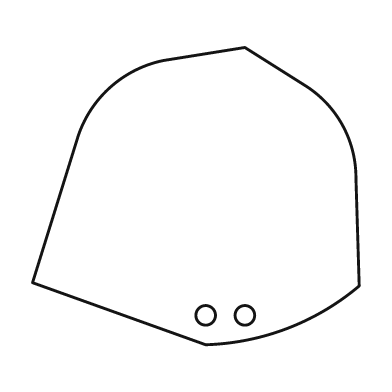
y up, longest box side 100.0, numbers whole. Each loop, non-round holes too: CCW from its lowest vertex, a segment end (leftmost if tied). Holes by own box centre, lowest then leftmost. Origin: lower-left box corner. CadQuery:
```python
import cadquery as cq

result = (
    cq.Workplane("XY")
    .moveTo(53.0, 0.0)
    .threePointArc((78.0, 5.0), (100.0, 18.0))
    .lineTo(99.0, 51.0)
    .threePointArc((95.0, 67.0), (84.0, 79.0))
    .lineTo(65.0, 91.0)
    .lineTo(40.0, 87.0)
    .threePointArc((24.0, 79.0), (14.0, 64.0))
    .lineTo(0.0, 19.0)
    .close()
    .moveTo(53.0, 9.0)
    .circle(3.0)
    .moveTo(65.0, 9.0)
    .circle(3.0)
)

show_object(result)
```